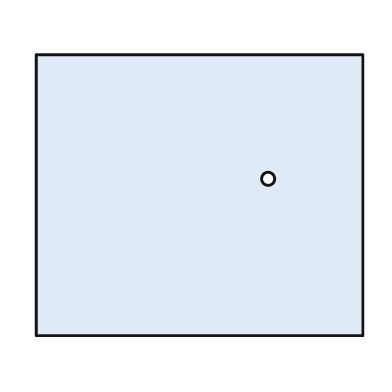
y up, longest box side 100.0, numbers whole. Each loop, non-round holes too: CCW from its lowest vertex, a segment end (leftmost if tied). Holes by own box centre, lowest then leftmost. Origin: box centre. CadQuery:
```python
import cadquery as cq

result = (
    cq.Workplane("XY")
    .moveTo(-50.0, -43.0)
    .lineTo(50.0, -43.0)
    .lineTo(50.0, 43.0)
    .lineTo(-50.0, 43.0)
    .close()
    .moveTo(21.0, 5.0)
    .circle(2.0)
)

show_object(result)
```